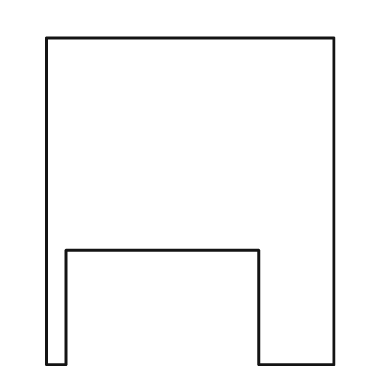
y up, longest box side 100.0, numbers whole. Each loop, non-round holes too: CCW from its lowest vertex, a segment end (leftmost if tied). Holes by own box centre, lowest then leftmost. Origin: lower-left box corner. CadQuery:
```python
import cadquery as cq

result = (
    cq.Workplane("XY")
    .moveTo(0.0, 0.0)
    .lineTo(6.0, 0.0)
    .lineTo(6.0, 35.0)
    .lineTo(65.0, 35.0)
    .lineTo(65.0, 0.0)
    .lineTo(88.0, 0.0)
    .lineTo(88.0, 100.0)
    .lineTo(0.0, 100.0)
    .close()
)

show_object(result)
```